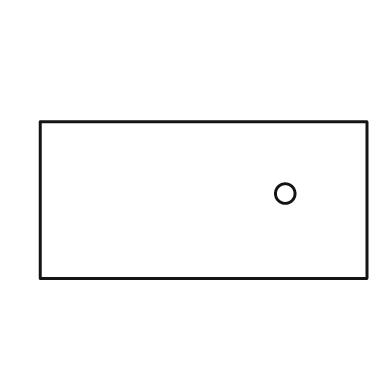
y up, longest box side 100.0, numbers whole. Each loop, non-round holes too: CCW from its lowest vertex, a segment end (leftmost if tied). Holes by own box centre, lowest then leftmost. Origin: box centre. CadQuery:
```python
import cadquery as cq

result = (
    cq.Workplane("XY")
    .moveTo(-50.0, -24.0)
    .lineTo(50.0, -24.0)
    .lineTo(50.0, 24.0)
    .lineTo(-50.0, 24.0)
    .close()
    .moveTo(25.0, 2.0)
    .circle(3.0)
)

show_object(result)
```